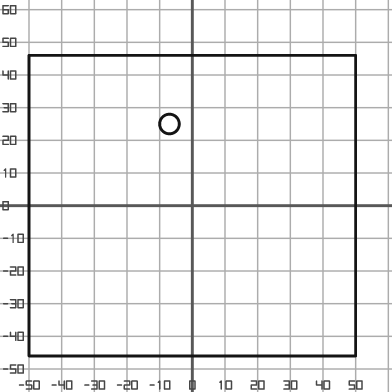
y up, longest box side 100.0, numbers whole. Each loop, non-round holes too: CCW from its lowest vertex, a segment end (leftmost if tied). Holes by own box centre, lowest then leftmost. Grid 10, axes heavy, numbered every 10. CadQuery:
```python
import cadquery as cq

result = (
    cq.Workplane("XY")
    .moveTo(-50.0, -46.0)
    .lineTo(50.0, -46.0)
    .lineTo(50.0, 46.0)
    .lineTo(-50.0, 46.0)
    .close()
    .moveTo(-7.0, 25.0)
    .circle(3.0)
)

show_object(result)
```